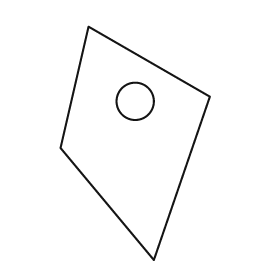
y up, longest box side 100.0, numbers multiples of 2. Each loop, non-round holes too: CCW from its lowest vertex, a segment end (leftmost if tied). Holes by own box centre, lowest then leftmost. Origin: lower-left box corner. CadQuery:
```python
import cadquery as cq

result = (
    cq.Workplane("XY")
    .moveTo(40.0, 0.0)
    .lineTo(64.0, 70.0)
    .lineTo(12.0, 100.0)
    .lineTo(0.0, 48.0)
    .close()
    .moveTo(32.0, 68.0)
    .circle(8.0)
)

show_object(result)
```